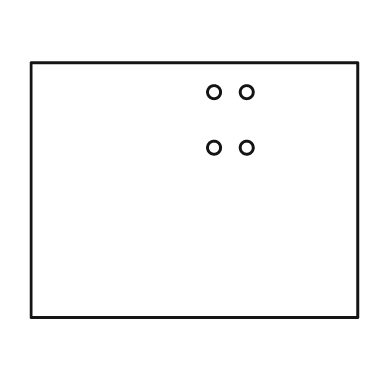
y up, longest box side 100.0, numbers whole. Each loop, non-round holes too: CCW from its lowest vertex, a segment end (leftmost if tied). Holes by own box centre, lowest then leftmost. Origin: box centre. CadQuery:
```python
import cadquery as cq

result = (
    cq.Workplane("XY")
    .moveTo(-50.0, -39.0)
    .lineTo(50.0, -39.0)
    .lineTo(50.0, 39.0)
    .lineTo(-50.0, 39.0)
    .close()
    .moveTo(6.0, 13.0)
    .circle(2.0)
    .moveTo(16.0, 13.0)
    .circle(2.0)
    .moveTo(6.0, 30.0)
    .circle(2.0)
    .moveTo(16.0, 30.0)
    .circle(2.0)
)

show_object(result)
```